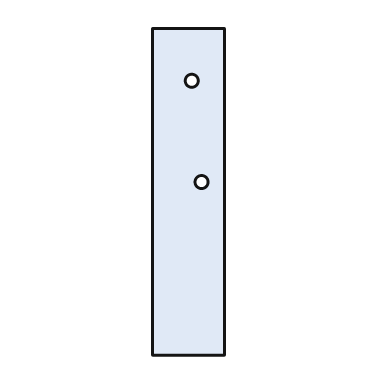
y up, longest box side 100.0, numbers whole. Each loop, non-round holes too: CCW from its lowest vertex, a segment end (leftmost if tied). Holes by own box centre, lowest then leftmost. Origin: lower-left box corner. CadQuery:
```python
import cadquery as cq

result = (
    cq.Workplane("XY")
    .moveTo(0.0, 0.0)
    .lineTo(22.0, 0.0)
    .lineTo(22.0, 100.0)
    .lineTo(0.0, 100.0)
    .close()
    .moveTo(15.0, 53.0)
    .circle(2.0)
    .moveTo(12.0, 84.0)
    .circle(2.0)
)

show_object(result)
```